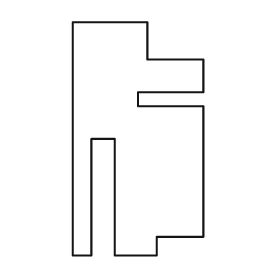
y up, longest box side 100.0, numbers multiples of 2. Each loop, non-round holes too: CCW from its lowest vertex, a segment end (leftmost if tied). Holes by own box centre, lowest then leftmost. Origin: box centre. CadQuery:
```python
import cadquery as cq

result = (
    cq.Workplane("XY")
    .moveTo(-28.0, -50.0)
    .lineTo(-20.0, -50.0)
    .lineTo(-20.0, 0.0)
    .lineTo(-10.0, 0.0)
    .lineTo(-10.0, -50.0)
    .lineTo(8.0, -50.0)
    .lineTo(8.0, -42.0)
    .lineTo(28.0, -42.0)
    .lineTo(28.0, 14.0)
    .lineTo(0.0, 14.0)
    .lineTo(0.0, 20.0)
    .lineTo(28.0, 20.0)
    .lineTo(28.0, 34.0)
    .lineTo(4.0, 34.0)
    .lineTo(4.0, 50.0)
    .lineTo(-28.0, 50.0)
    .close()
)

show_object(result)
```